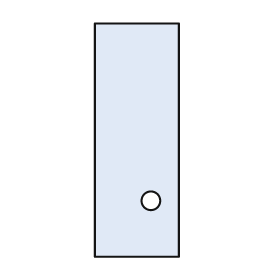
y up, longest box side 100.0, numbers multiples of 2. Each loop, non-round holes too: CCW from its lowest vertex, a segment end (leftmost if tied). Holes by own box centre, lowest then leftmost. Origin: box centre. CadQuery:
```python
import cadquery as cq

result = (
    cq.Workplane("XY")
    .moveTo(-18.0, -50.0)
    .lineTo(18.0, -50.0)
    .lineTo(18.0, 50.0)
    .lineTo(-18.0, 50.0)
    .close()
    .moveTo(6.0, -26.0)
    .circle(4.0)
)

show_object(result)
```